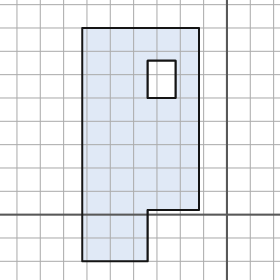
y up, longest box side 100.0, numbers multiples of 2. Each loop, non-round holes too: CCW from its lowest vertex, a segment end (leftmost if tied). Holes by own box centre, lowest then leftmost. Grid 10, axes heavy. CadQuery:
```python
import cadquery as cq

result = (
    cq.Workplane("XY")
    .moveTo(-62.0, -20.0)
    .lineTo(-34.0, -20.0)
    .lineTo(-34.0, 2.0)
    .lineTo(-12.0, 2.0)
    .lineTo(-12.0, 80.0)
    .lineTo(-62.0, 80.0)
    .close()
    .moveTo(-34.0, 50.0)
    .lineTo(-22.0, 50.0)
    .lineTo(-22.0, 66.0)
    .lineTo(-34.0, 66.0)
    .close()
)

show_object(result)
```